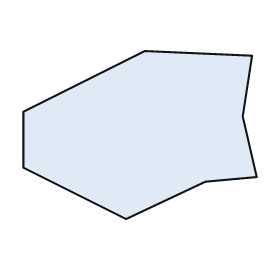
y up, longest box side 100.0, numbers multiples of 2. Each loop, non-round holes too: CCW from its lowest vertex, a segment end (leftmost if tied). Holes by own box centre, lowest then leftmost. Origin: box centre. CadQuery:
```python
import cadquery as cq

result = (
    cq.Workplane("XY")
    .moveTo(-6.0, -36.0)
    .lineTo(28.0, -20.0)
    .lineTo(50.0, -18.0)
    .lineTo(44.0, 8.0)
    .lineTo(48.0, 34.0)
    .lineTo(2.0, 36.0)
    .lineTo(-50.0, 10.0)
    .lineTo(-50.0, -14.0)
    .close()
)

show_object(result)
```